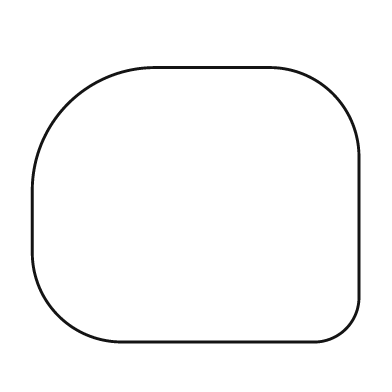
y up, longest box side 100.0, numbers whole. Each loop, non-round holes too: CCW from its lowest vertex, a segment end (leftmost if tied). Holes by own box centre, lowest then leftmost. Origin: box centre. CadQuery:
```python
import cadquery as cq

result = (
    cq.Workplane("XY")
    .moveTo(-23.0, -42.0)
    .lineTo(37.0, -42.0)
    .threePointArc((46.0, -38.0), (50.0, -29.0))
    .lineTo(50.0, 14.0)
    .threePointArc((42.0, 34.0), (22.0, 42.0))
    .lineTo(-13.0, 42.0)
    .threePointArc((-39.0, 31.0), (-50.0, 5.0))
    .lineTo(-50.0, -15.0)
    .threePointArc((-42.0, -34.0), (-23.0, -42.0))
    .close()
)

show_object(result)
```